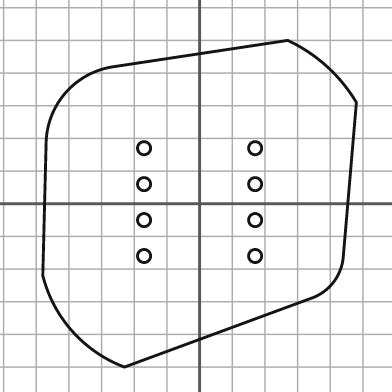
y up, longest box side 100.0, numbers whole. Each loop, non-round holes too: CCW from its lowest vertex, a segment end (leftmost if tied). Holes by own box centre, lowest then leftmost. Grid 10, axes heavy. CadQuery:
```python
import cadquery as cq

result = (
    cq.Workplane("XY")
    .moveTo(-23.0, -50.0)
    .lineTo(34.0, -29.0)
    .threePointArc((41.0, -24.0), (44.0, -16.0))
    .lineTo(48.0, 31.0)
    .threePointArc((39.0, 42.0), (27.0, 50.0))
    .lineTo(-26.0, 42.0)
    .threePointArc((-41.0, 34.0), (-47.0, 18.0))
    .lineTo(-48.0, -22.0)
    .threePointArc((-39.0, -39.0), (-23.0, -50.0))
    .close()
    .moveTo(-17.0, -16.0)
    .circle(2.0)
    .moveTo(17.0, -16.0)
    .circle(2.0)
    .moveTo(-17.0, -5.0)
    .circle(2.0)
    .moveTo(17.0, -5.0)
    .circle(2.0)
    .moveTo(-17.0, 6.0)
    .circle(2.0)
    .moveTo(17.0, 6.0)
    .circle(2.0)
    .moveTo(-17.0, 17.0)
    .circle(2.0)
    .moveTo(17.0, 17.0)
    .circle(2.0)
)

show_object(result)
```